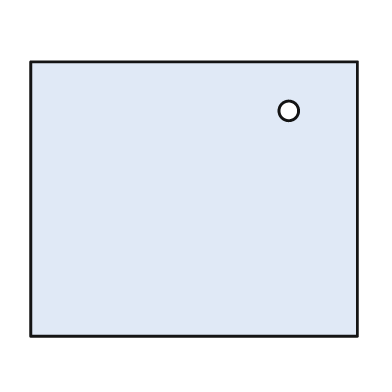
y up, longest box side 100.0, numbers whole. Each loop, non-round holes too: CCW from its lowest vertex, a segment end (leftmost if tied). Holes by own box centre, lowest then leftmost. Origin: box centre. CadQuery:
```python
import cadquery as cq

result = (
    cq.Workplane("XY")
    .moveTo(-50.0, -42.0)
    .lineTo(50.0, -42.0)
    .lineTo(50.0, 42.0)
    .lineTo(-50.0, 42.0)
    .close()
    .moveTo(29.0, 27.0)
    .circle(3.0)
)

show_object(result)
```